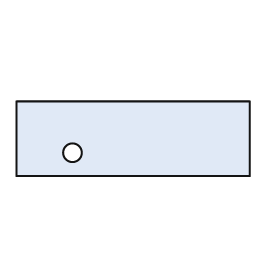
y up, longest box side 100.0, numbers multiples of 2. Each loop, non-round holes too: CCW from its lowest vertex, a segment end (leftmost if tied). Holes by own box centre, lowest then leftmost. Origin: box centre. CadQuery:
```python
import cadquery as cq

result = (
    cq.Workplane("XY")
    .moveTo(-50.0, -16.0)
    .lineTo(50.0, -16.0)
    .lineTo(50.0, 16.0)
    .lineTo(-50.0, 16.0)
    .close()
    .moveTo(-26.0, -6.0)
    .circle(4.0)
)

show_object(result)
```